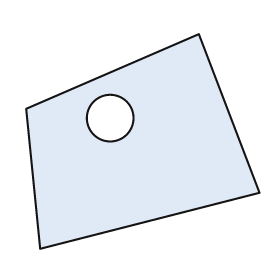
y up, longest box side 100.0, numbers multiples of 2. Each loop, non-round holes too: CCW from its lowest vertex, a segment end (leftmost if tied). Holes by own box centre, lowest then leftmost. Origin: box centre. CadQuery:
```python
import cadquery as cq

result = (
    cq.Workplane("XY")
    .moveTo(-44.0, -46.0)
    .lineTo(50.0, -22.0)
    .lineTo(24.0, 46.0)
    .lineTo(-50.0, 14.0)
    .close()
    .moveTo(-14.0, 10.0)
    .circle(10.0)
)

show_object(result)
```